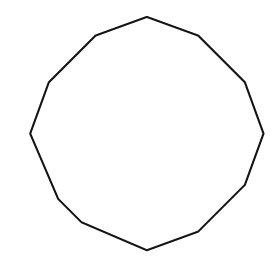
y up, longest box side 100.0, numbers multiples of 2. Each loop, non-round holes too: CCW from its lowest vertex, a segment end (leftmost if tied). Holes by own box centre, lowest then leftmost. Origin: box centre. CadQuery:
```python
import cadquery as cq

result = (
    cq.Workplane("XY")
    .moveTo(0.0, -50.0)
    .lineTo(22.0, -42.0)
    .lineTo(42.0, -22.0)
    .lineTo(50.0, 0.0)
    .lineTo(42.0, 22.0)
    .lineTo(22.0, 42.0)
    .lineTo(0.0, 50.0)
    .lineTo(-22.0, 42.0)
    .lineTo(-42.0, 22.0)
    .lineTo(-50.0, 0.0)
    .lineTo(-38.0, -28.0)
    .lineTo(-28.0, -38.0)
    .close()
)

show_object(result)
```